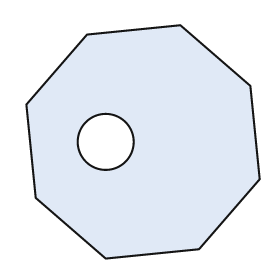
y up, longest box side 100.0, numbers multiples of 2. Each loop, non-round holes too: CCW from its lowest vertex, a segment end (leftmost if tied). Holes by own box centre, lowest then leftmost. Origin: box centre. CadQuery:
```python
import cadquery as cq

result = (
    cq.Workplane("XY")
    .moveTo(-16.0, -50.0)
    .lineTo(24.0, -46.0)
    .lineTo(50.0, -16.0)
    .lineTo(46.0, 24.0)
    .lineTo(16.0, 50.0)
    .lineTo(-24.0, 46.0)
    .lineTo(-50.0, 16.0)
    .lineTo(-46.0, -24.0)
    .close()
    .moveTo(-16.0, 0.0)
    .circle(12.0)
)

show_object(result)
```